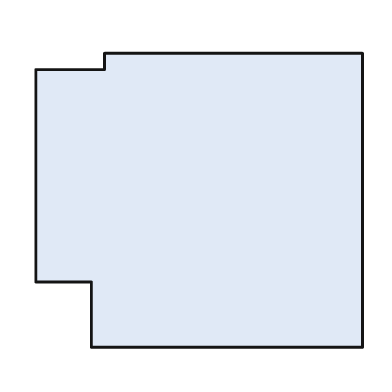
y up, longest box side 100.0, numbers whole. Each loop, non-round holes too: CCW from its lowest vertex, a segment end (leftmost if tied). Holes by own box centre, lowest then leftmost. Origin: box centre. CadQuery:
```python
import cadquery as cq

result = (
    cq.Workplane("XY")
    .moveTo(-33.0, -45.0)
    .lineTo(50.0, -45.0)
    .lineTo(50.0, 45.0)
    .lineTo(-29.0, 45.0)
    .lineTo(-29.0, 40.0)
    .lineTo(-50.0, 40.0)
    .lineTo(-50.0, -25.0)
    .lineTo(-33.0, -25.0)
    .close()
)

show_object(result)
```